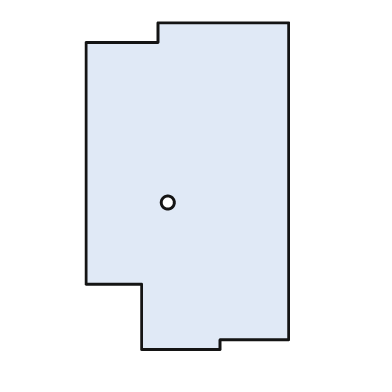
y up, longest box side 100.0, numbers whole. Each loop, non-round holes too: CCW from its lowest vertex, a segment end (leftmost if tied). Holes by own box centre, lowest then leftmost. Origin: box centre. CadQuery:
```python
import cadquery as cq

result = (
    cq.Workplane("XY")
    .moveTo(-14.0, -50.0)
    .lineTo(10.0, -50.0)
    .lineTo(10.0, -47.0)
    .lineTo(31.0, -47.0)
    .lineTo(31.0, 50.0)
    .lineTo(-9.0, 50.0)
    .lineTo(-9.0, 44.0)
    .lineTo(-31.0, 44.0)
    .lineTo(-31.0, -30.0)
    .lineTo(-14.0, -30.0)
    .close()
    .moveTo(-6.0, -5.0)
    .circle(2.0)
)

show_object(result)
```